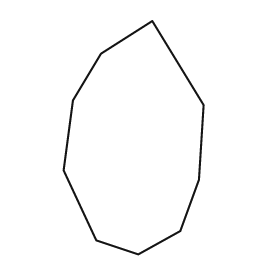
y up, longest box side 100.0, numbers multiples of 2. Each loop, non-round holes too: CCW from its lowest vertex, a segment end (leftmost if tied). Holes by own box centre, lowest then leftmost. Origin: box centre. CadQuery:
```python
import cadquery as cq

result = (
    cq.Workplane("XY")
    .moveTo(2.0, -50.0)
    .lineTo(20.0, -40.0)
    .lineTo(28.0, -18.0)
    .lineTo(30.0, 14.0)
    .lineTo(8.0, 50.0)
    .lineTo(-14.0, 36.0)
    .lineTo(-26.0, 16.0)
    .lineTo(-30.0, -14.0)
    .lineTo(-16.0, -44.0)
    .close()
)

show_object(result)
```